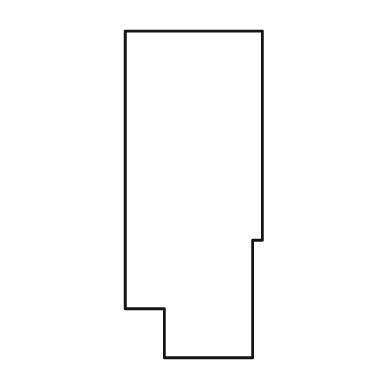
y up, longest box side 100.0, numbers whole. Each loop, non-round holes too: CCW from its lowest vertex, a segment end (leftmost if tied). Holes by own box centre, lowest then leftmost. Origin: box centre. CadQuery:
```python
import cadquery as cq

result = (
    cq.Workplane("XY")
    .moveTo(-9.0, -50.0)
    .lineTo(18.0, -50.0)
    .lineTo(18.0, -14.0)
    .lineTo(21.0, -14.0)
    .lineTo(21.0, 50.0)
    .lineTo(-21.0, 50.0)
    .lineTo(-21.0, -35.0)
    .lineTo(-9.0, -35.0)
    .close()
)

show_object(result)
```